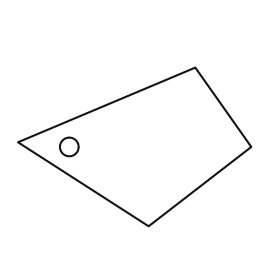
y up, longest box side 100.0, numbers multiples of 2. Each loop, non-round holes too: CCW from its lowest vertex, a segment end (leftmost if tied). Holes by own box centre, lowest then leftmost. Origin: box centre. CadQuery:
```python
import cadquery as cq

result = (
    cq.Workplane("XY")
    .moveTo(6.0, -34.0)
    .lineTo(50.0, 0.0)
    .lineTo(26.0, 34.0)
    .lineTo(-50.0, 2.0)
    .close()
    .moveTo(-28.0, 0.0)
    .circle(4.0)
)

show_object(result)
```